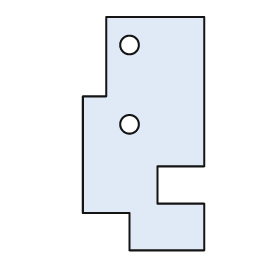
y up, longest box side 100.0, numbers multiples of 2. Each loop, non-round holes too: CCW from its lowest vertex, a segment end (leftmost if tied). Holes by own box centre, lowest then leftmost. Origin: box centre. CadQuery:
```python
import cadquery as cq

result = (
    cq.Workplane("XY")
    .moveTo(-6.0, -50.0)
    .lineTo(26.0, -50.0)
    .lineTo(26.0, -30.0)
    .lineTo(6.0, -30.0)
    .lineTo(6.0, -14.0)
    .lineTo(26.0, -14.0)
    .lineTo(26.0, 50.0)
    .lineTo(-16.0, 50.0)
    .lineTo(-16.0, 16.0)
    .lineTo(-26.0, 16.0)
    .lineTo(-26.0, -34.0)
    .lineTo(-6.0, -34.0)
    .close()
    .moveTo(-6.0, 4.0)
    .circle(4.0)
    .moveTo(-6.0, 38.0)
    .circle(4.0)
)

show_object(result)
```